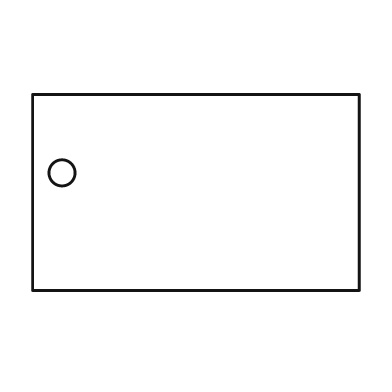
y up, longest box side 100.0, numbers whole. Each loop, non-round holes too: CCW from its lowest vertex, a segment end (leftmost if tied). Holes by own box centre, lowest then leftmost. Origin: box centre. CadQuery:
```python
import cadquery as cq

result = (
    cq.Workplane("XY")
    .moveTo(-50.0, -30.0)
    .lineTo(50.0, -30.0)
    .lineTo(50.0, 30.0)
    .lineTo(-50.0, 30.0)
    .close()
    .moveTo(-41.0, 6.0)
    .circle(4.0)
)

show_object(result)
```